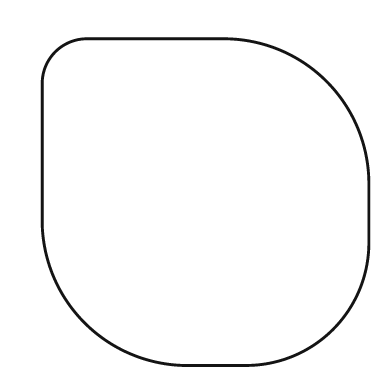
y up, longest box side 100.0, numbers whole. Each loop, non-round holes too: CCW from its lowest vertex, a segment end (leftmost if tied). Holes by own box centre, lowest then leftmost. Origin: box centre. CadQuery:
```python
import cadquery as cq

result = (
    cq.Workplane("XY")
    .moveTo(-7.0, -50.0)
    .lineTo(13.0, -50.0)
    .threePointArc((39.0, -39.0), (50.0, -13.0))
    .lineTo(50.0, 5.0)
    .threePointArc((37.0, 37.0), (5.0, 50.0))
    .lineTo(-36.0, 50.0)
    .threePointArc((-46.0, 46.0), (-50.0, 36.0))
    .lineTo(-50.0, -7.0)
    .threePointArc((-37.0, -37.0), (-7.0, -50.0))
    .close()
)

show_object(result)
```